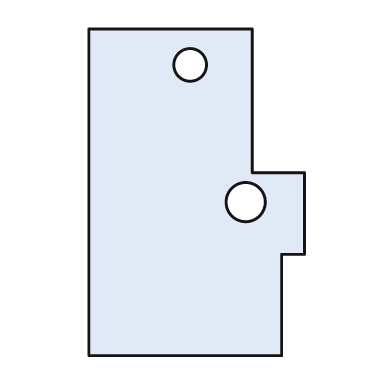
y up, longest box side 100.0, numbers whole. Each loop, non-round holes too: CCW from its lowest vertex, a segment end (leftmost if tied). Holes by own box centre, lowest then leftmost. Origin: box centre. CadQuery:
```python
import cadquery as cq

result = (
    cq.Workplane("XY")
    .moveTo(-33.0, -50.0)
    .lineTo(26.0, -50.0)
    .lineTo(26.0, -19.0)
    .lineTo(33.0, -19.0)
    .lineTo(33.0, 6.0)
    .lineTo(17.0, 6.0)
    .lineTo(17.0, 50.0)
    .lineTo(-33.0, 50.0)
    .close()
    .moveTo(15.0, -3.0)
    .circle(6.0)
    .moveTo(-2.0, 39.0)
    .circle(5.0)
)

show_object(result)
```